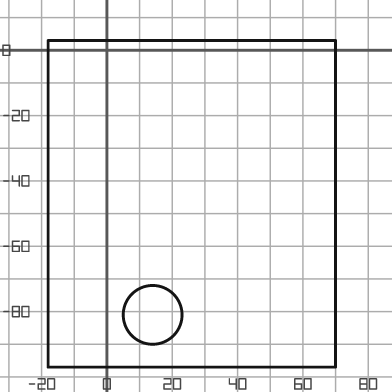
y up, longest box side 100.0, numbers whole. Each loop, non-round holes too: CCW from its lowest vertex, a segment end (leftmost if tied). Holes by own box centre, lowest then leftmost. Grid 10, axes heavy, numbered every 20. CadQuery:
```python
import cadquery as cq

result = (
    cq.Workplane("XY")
    .moveTo(-18.0, -97.0)
    .lineTo(70.0, -97.0)
    .lineTo(70.0, 3.0)
    .lineTo(-18.0, 3.0)
    .close()
    .moveTo(14.0, -81.0)
    .circle(9.0)
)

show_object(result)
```